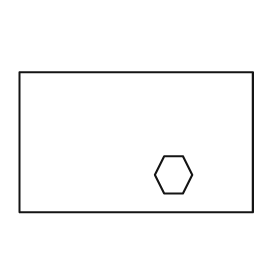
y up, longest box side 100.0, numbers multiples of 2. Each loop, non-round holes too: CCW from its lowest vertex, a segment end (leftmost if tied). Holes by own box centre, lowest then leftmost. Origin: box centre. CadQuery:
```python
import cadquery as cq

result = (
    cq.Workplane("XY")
    .moveTo(-50.0, -30.0)
    .lineTo(50.0, -30.0)
    .lineTo(50.0, 30.0)
    .lineTo(-50.0, 30.0)
    .close()
    .moveTo(12.0, -22.0)
    .lineTo(20.0, -22.0)
    .lineTo(24.0, -14.0)
    .lineTo(20.0, -6.0)
    .lineTo(12.0, -6.0)
    .lineTo(8.0, -14.0)
    .close()
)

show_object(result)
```